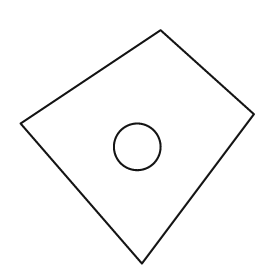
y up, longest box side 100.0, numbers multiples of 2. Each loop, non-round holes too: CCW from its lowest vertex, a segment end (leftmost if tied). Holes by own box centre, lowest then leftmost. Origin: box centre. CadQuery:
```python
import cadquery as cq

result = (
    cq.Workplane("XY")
    .moveTo(2.0, -50.0)
    .lineTo(50.0, 14.0)
    .lineTo(10.0, 50.0)
    .lineTo(-50.0, 10.0)
    .close()
    .moveTo(0.0, 0.0)
    .circle(10.0)
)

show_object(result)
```